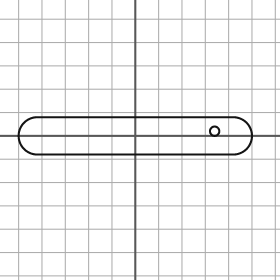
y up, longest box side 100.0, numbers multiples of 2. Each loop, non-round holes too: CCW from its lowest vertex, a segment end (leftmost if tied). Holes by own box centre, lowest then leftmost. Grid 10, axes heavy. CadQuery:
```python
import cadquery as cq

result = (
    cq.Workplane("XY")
    .moveTo(-42.0, -8.0)
    .lineTo(42.0, -8.0)
    .threePointArc((50.0, 0.0), (42.0, 8.0))
    .lineTo(-42.0, 8.0)
    .threePointArc((-50.0, 0.0), (-42.0, -8.0))
    .close()
    .moveTo(34.0, 2.0)
    .circle(2.0)
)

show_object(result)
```